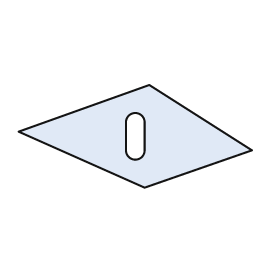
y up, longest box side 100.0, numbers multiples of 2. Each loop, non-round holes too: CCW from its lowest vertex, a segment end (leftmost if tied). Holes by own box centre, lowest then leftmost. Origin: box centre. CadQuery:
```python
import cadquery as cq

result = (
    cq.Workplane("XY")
    .moveTo(4.0, -22.0)
    .lineTo(50.0, -6.0)
    .lineTo(6.0, 22.0)
    .lineTo(-50.0, 2.0)
    .close()
    .moveTo(-4.0, -6.0)
    .threePointArc((0.0, -10.0), (4.0, -6.0))
    .lineTo(4.0, 6.0)
    .threePointArc((0.0, 10.0), (-4.0, 6.0))
    .close()
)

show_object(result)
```